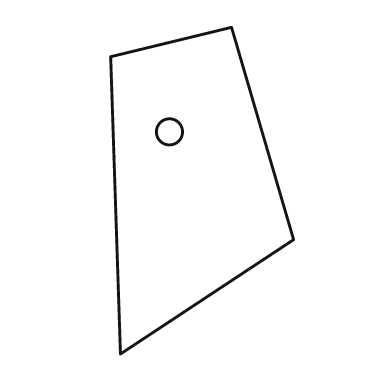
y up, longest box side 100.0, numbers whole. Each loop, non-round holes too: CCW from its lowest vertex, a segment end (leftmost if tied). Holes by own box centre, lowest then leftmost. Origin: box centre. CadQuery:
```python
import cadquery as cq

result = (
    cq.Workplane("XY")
    .moveTo(-25.0, -50.0)
    .lineTo(28.0, -15.0)
    .lineTo(9.0, 50.0)
    .lineTo(-28.0, 41.0)
    .close()
    .moveTo(-10.0, 18.0)
    .circle(4.0)
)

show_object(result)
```